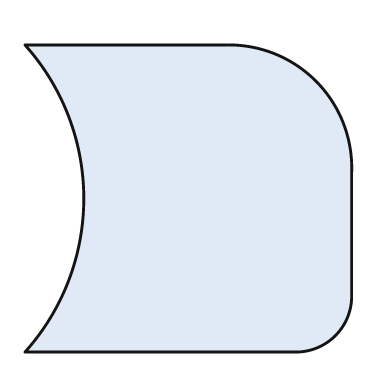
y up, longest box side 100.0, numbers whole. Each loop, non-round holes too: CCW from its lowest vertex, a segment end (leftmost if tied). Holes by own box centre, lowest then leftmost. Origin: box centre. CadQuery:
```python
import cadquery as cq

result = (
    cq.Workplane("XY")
    .moveTo(-50.0, -47.0)
    .lineTo(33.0, -47.0)
    .threePointArc((45.0, -42.0), (50.0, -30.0))
    .lineTo(50.0, 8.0)
    .threePointArc((39.0, 36.0), (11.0, 47.0))
    .lineTo(-50.0, 47.0)
    .threePointArc((-32.0, 0.0), (-50.0, -47.0))
    .close()
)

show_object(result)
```